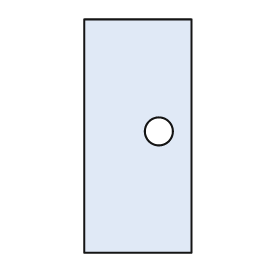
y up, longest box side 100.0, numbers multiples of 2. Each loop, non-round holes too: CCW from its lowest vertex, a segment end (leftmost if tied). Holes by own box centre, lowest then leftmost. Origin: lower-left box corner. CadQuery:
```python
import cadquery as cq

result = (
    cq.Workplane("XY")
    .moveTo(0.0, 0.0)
    .lineTo(46.0, 0.0)
    .lineTo(46.0, 100.0)
    .lineTo(0.0, 100.0)
    .close()
    .moveTo(32.0, 52.0)
    .circle(6.0)
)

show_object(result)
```